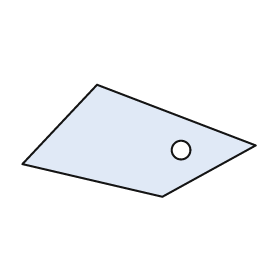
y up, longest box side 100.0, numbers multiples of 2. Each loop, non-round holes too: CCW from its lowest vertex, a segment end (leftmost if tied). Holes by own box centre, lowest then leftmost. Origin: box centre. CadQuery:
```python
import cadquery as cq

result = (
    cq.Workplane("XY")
    .moveTo(10.0, -24.0)
    .lineTo(50.0, -2.0)
    .lineTo(-18.0, 24.0)
    .lineTo(-50.0, -10.0)
    .close()
    .moveTo(18.0, -4.0)
    .circle(4.0)
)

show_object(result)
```